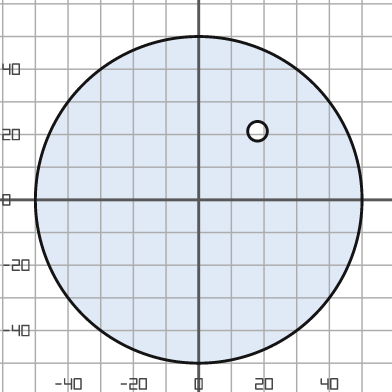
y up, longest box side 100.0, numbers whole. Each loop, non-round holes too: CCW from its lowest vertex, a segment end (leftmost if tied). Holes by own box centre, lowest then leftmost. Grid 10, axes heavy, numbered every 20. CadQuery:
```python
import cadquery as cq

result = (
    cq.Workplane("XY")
    .moveTo(0.0, 0.0)
    .circle(50.0)
    .moveTo(18.0, 21.0)
    .circle(3.0)
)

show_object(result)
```